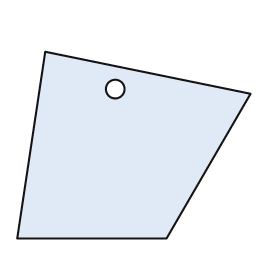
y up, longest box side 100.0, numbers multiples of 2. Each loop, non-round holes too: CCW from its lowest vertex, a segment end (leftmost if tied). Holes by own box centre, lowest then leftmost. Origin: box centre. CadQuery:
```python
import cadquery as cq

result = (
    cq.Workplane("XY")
    .moveTo(-50.0, -40.0)
    .lineTo(14.0, -40.0)
    .lineTo(50.0, 22.0)
    .lineTo(-38.0, 40.0)
    .close()
    .moveTo(-8.0, 24.0)
    .circle(4.0)
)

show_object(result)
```